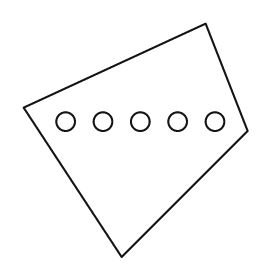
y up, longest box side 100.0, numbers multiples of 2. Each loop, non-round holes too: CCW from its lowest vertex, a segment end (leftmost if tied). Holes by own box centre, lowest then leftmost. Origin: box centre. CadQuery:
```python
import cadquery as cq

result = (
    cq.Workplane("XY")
    .moveTo(-6.0, -50.0)
    .lineTo(48.0, 4.0)
    .lineTo(30.0, 50.0)
    .lineTo(-48.0, 14.0)
    .close()
    .moveTo(-30.0, 8.0)
    .circle(4.0)
    .moveTo(-14.0, 8.0)
    .circle(4.0)
    .moveTo(2.0, 8.0)
    .circle(4.0)
    .moveTo(18.0, 8.0)
    .circle(4.0)
    .moveTo(34.0, 8.0)
    .circle(4.0)
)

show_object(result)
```